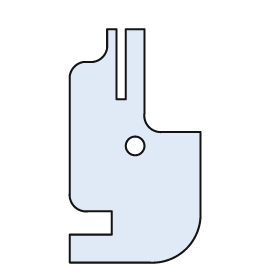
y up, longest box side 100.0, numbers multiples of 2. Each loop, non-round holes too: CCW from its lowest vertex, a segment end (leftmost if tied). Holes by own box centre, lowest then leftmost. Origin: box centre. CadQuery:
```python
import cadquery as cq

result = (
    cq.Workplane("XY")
    .moveTo(-28.0, -50.0)
    .lineTo(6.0, -50.0)
    .threePointArc((22.0, -44.0), (28.0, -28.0))
    .lineTo(28.0, 6.0)
    .lineTo(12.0, 6.0)
    .threePointArc((6.0, 8.0), (4.0, 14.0))
    .lineTo(4.0, 50.0)
    .lineTo(-4.0, 50.0)
    .lineTo(-4.0, 20.0)
    .lineTo(-8.0, 20.0)
    .lineTo(-8.0, 50.0)
    .lineTo(-12.0, 50.0)
    .lineTo(-12.0, 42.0)
    .threePointArc((-14.0, 38.0), (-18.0, 36.0))
    .lineTo(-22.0, 36.0)
    .threePointArc((-26.0, 34.0), (-28.0, 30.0))
    .lineTo(-28.0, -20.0)
    .threePointArc((-26.0, -26.0), (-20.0, -28.0))
    .lineTo(-10.0, -28.0)
    .lineTo(-10.0, -38.0)
    .lineTo(-28.0, -38.0)
    .close()
    .moveTo(0.0, 0.0)
    .circle(4.0)
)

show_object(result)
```